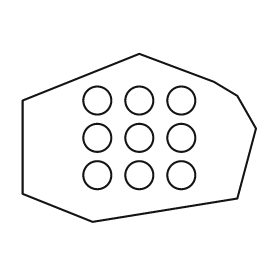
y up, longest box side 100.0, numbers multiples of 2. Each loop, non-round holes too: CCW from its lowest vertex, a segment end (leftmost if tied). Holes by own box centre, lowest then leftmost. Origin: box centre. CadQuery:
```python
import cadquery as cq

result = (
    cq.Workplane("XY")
    .moveTo(-20.0, -36.0)
    .lineTo(42.0, -26.0)
    .lineTo(50.0, 4.0)
    .lineTo(42.0, 18.0)
    .lineTo(32.0, 24.0)
    .lineTo(0.0, 36.0)
    .lineTo(-50.0, 16.0)
    .lineTo(-50.0, -24.0)
    .close()
    .moveTo(-18.0, -16.0)
    .circle(6.0)
    .moveTo(0.0, -16.0)
    .circle(6.0)
    .moveTo(18.0, -16.0)
    .circle(6.0)
    .moveTo(-18.0, 0.0)
    .circle(6.0)
    .moveTo(0.0, 0.0)
    .circle(6.0)
    .moveTo(18.0, 0.0)
    .circle(6.0)
    .moveTo(-18.0, 16.0)
    .circle(6.0)
    .moveTo(0.0, 16.0)
    .circle(6.0)
    .moveTo(18.0, 16.0)
    .circle(6.0)
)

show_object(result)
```